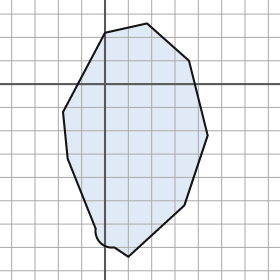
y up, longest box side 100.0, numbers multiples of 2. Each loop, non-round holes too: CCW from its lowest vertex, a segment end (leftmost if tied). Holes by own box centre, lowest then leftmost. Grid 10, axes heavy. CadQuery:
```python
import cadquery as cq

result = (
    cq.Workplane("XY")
    .moveTo(10.0, -74.0)
    .lineTo(34.0, -52.0)
    .lineTo(44.0, -22.0)
    .lineTo(36.0, 10.0)
    .lineTo(18.0, 26.0)
    .lineTo(0.0, 22.0)
    .lineTo(-18.0, -12.0)
    .lineTo(-16.0, -32.0)
    .lineTo(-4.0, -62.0)
    .threePointArc((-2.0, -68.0), (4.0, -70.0))
    .close()
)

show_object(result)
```